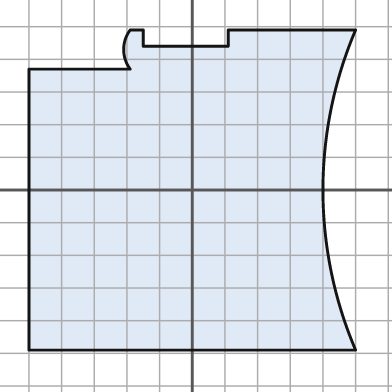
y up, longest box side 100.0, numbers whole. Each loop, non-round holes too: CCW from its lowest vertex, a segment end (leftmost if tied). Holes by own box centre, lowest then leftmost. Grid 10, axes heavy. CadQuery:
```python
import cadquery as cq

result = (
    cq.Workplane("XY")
    .moveTo(-50.0, -49.0)
    .lineTo(50.0, -49.0)
    .threePointArc((40.0, 0.0), (50.0, 49.0))
    .lineTo(11.0, 49.0)
    .lineTo(11.0, 44.0)
    .lineTo(-15.0, 44.0)
    .lineTo(-15.0, 49.0)
    .lineTo(-19.0, 49.0)
    .threePointArc((-21.0, 43.0), (-19.0, 37.0))
    .lineTo(-50.0, 37.0)
    .close()
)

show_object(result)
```